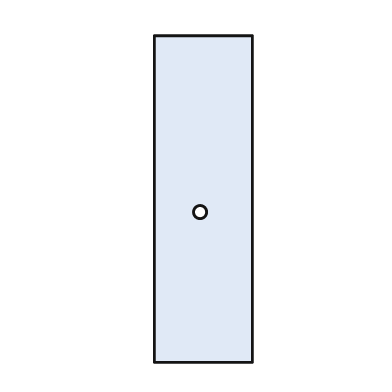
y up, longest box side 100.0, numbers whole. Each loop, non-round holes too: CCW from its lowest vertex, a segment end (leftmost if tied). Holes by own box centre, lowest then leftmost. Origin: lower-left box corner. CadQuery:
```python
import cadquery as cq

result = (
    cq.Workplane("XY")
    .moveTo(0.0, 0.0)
    .lineTo(30.0, 0.0)
    .lineTo(30.0, 100.0)
    .lineTo(0.0, 100.0)
    .close()
    .moveTo(14.0, 46.0)
    .circle(2.0)
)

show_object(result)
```